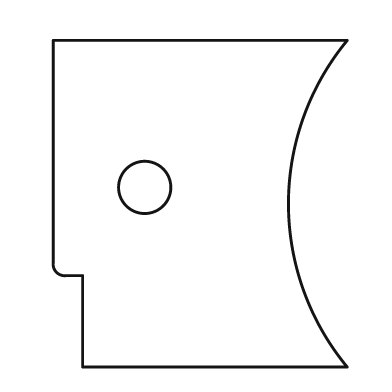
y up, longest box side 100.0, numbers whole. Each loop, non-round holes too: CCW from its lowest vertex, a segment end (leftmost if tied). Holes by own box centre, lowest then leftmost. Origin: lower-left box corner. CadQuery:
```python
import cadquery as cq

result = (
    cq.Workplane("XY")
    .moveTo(9.0, 0.0)
    .lineTo(90.0, 0.0)
    .threePointArc((72.0, 50.0), (90.0, 100.0))
    .lineTo(0.0, 100.0)
    .lineTo(0.0, 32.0)
    .threePointArc((1.0, 29.0), (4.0, 28.0))
    .lineTo(9.0, 28.0)
    .close()
    .moveTo(28.0, 55.0)
    .circle(8.0)
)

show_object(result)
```